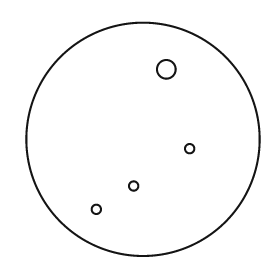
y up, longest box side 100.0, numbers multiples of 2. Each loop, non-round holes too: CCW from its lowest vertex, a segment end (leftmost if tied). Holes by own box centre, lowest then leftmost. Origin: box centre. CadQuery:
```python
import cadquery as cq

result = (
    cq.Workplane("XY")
    .moveTo(0.0, 0.0)
    .circle(50.0)
    .moveTo(-20.0, -30.0)
    .circle(2.0)
    .moveTo(-4.0, -20.0)
    .circle(2.0)
    .moveTo(20.0, -4.0)
    .circle(2.0)
    .moveTo(10.0, 30.0)
    .circle(4.0)
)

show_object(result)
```